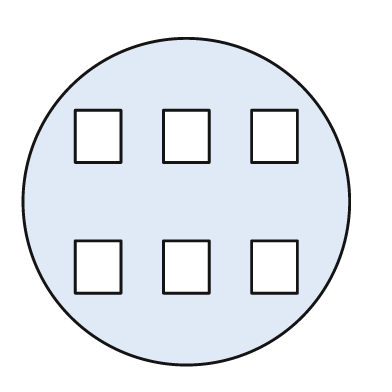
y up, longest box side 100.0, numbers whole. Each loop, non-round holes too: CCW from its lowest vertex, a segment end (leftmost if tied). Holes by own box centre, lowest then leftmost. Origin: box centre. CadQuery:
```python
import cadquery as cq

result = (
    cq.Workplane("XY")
    .moveTo(0.0, 0.0)
    .circle(50.0)
    .moveTo(-34.0, -28.0)
    .lineTo(-20.0, -28.0)
    .lineTo(-20.0, -12.0)
    .lineTo(-34.0, -12.0)
    .close()
    .moveTo(-7.0, -28.0)
    .lineTo(7.0, -28.0)
    .lineTo(7.0, -12.0)
    .lineTo(-7.0, -12.0)
    .close()
    .moveTo(20.0, -28.0)
    .lineTo(34.0, -28.0)
    .lineTo(34.0, -12.0)
    .lineTo(20.0, -12.0)
    .close()
    .moveTo(-34.0, 12.0)
    .lineTo(-20.0, 12.0)
    .lineTo(-20.0, 28.0)
    .lineTo(-34.0, 28.0)
    .close()
    .moveTo(-7.0, 12.0)
    .lineTo(7.0, 12.0)
    .lineTo(7.0, 28.0)
    .lineTo(-7.0, 28.0)
    .close()
    .moveTo(20.0, 12.0)
    .lineTo(34.0, 12.0)
    .lineTo(34.0, 28.0)
    .lineTo(20.0, 28.0)
    .close()
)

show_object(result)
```